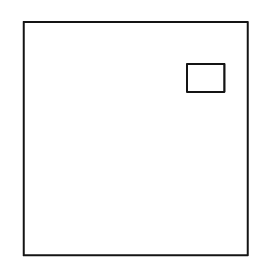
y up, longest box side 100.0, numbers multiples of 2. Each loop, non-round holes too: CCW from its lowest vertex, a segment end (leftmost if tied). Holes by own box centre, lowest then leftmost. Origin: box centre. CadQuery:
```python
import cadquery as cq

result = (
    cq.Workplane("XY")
    .moveTo(-48.0, -50.0)
    .lineTo(48.0, -50.0)
    .lineTo(48.0, 50.0)
    .lineTo(-48.0, 50.0)
    .close()
    .moveTo(22.0, 20.0)
    .lineTo(38.0, 20.0)
    .lineTo(38.0, 32.0)
    .lineTo(22.0, 32.0)
    .close()
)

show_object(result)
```